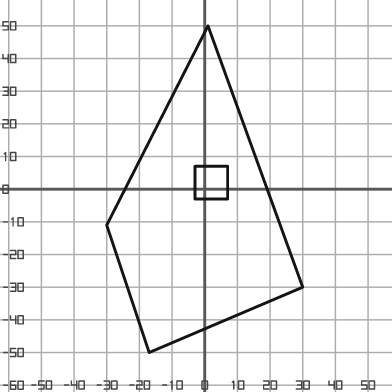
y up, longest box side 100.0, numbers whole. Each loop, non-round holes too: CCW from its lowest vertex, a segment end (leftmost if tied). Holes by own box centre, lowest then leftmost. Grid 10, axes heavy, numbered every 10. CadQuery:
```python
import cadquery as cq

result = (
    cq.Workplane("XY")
    .moveTo(-17.0, -50.0)
    .lineTo(30.0, -30.0)
    .lineTo(1.0, 50.0)
    .lineTo(-30.0, -11.0)
    .close()
    .moveTo(-3.0, -3.0)
    .lineTo(7.0, -3.0)
    .lineTo(7.0, 7.0)
    .lineTo(-3.0, 7.0)
    .close()
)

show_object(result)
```